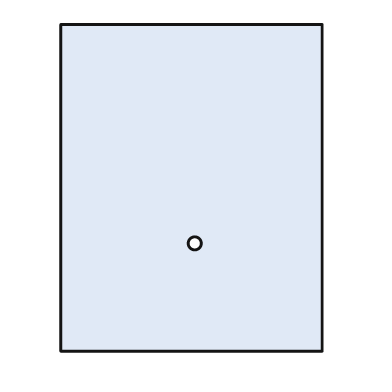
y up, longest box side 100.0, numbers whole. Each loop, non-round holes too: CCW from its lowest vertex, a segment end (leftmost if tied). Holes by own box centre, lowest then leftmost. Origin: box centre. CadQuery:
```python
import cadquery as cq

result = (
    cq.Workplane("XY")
    .moveTo(-40.0, -50.0)
    .lineTo(40.0, -50.0)
    .lineTo(40.0, 50.0)
    .lineTo(-40.0, 50.0)
    .close()
    .moveTo(1.0, -17.0)
    .circle(2.0)
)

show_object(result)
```